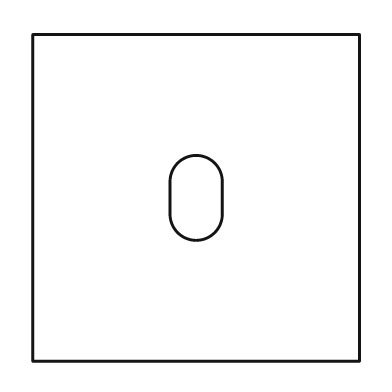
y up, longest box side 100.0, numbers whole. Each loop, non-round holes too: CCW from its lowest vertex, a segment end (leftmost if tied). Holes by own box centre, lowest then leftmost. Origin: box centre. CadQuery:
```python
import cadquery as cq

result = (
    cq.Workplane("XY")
    .moveTo(-50.0, -50.0)
    .lineTo(50.0, -50.0)
    .lineTo(50.0, 50.0)
    .lineTo(-50.0, 50.0)
    .close()
    .moveTo(-8.0, -5.0)
    .threePointArc((0.0, -13.0), (8.0, -5.0))
    .lineTo(8.0, 5.0)
    .threePointArc((0.0, 13.0), (-8.0, 5.0))
    .close()
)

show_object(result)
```